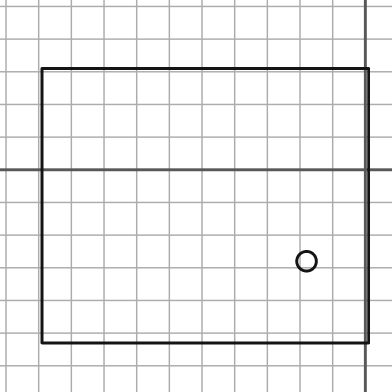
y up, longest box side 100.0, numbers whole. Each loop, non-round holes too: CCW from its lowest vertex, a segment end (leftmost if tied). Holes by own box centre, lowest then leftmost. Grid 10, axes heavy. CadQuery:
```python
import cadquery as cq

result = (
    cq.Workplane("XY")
    .moveTo(-99.0, -53.0)
    .lineTo(1.0, -53.0)
    .lineTo(1.0, 31.0)
    .lineTo(-99.0, 31.0)
    .close()
    .moveTo(-18.0, -28.0)
    .circle(3.0)
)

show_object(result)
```